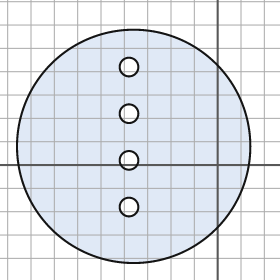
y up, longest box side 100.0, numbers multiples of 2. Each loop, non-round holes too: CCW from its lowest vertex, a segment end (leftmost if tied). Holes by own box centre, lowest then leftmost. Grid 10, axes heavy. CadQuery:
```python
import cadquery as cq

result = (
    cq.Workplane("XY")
    .moveTo(-36.0, 8.0)
    .circle(50.0)
    .moveTo(-38.0, -18.0)
    .circle(4.0)
    .moveTo(-38.0, 2.0)
    .circle(4.0)
    .moveTo(-38.0, 22.0)
    .circle(4.0)
    .moveTo(-38.0, 42.0)
    .circle(4.0)
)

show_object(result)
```